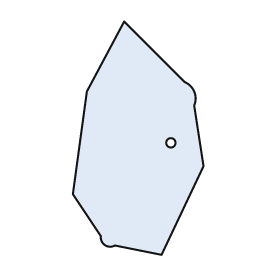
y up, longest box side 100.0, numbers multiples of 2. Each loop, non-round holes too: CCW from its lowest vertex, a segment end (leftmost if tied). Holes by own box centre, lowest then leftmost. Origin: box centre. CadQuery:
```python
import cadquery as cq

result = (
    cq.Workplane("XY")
    .moveTo(10.0, -50.0)
    .lineTo(28.0, -12.0)
    .lineTo(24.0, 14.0)
    .threePointArc((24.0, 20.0), (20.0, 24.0))
    .lineTo(-6.0, 50.0)
    .lineTo(-22.0, 20.0)
    .lineTo(-28.0, -24.0)
    .lineTo(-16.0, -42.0)
    .threePointArc((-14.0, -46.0), (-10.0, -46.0))
    .close()
    .moveTo(14.0, -2.0)
    .circle(2.0)
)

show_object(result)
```